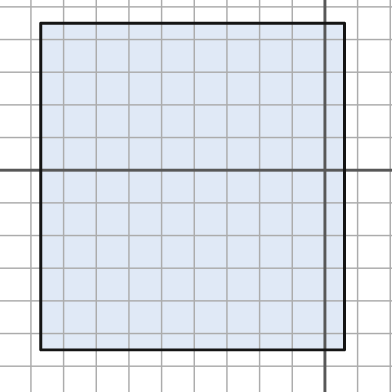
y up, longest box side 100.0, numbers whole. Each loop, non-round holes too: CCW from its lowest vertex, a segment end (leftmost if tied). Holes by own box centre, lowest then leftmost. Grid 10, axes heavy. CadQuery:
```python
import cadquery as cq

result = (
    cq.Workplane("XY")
    .moveTo(-87.0, -55.0)
    .lineTo(6.0, -55.0)
    .lineTo(6.0, 45.0)
    .lineTo(-87.0, 45.0)
    .close()
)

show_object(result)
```